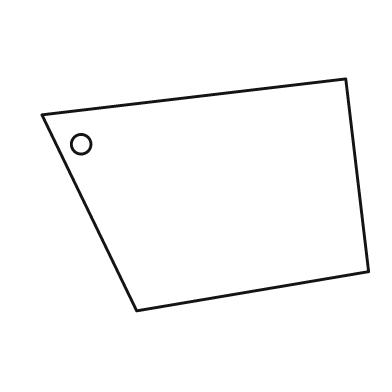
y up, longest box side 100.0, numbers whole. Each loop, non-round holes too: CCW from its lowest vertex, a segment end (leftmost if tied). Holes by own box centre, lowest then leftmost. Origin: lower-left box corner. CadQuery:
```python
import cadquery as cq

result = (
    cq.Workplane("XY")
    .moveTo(29.0, 0.0)
    .lineTo(100.0, 12.0)
    .lineTo(93.0, 71.0)
    .lineTo(0.0, 60.0)
    .close()
    .moveTo(12.0, 51.0)
    .circle(3.0)
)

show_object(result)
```